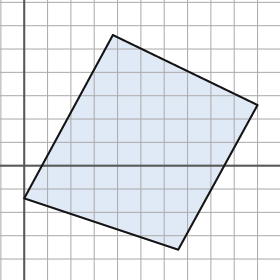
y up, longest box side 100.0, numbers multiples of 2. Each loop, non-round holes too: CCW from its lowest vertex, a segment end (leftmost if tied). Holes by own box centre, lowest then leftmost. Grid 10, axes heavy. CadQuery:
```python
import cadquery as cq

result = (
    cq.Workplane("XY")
    .moveTo(66.0, -36.0)
    .lineTo(100.0, 26.0)
    .lineTo(38.0, 56.0)
    .lineTo(0.0, -14.0)
    .close()
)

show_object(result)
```